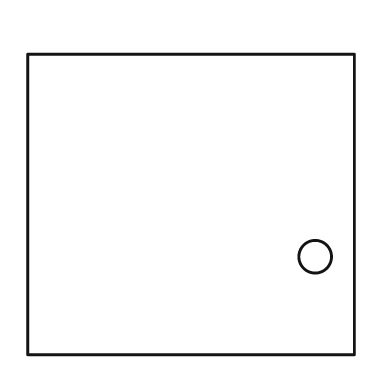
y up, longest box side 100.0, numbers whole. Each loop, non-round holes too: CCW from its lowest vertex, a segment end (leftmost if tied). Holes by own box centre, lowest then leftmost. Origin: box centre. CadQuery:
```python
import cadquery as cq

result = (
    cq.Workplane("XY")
    .moveTo(-50.0, -46.0)
    .lineTo(50.0, -46.0)
    .lineTo(50.0, 46.0)
    .lineTo(-50.0, 46.0)
    .close()
    .moveTo(38.0, -16.0)
    .circle(5.0)
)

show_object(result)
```